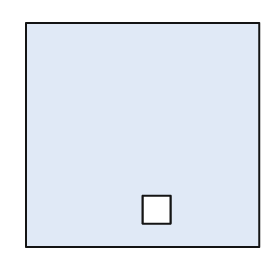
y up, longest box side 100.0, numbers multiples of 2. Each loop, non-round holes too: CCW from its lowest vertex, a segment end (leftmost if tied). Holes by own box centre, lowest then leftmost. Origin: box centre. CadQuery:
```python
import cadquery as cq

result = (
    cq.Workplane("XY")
    .moveTo(-50.0, -48.0)
    .lineTo(50.0, -48.0)
    .lineTo(50.0, 48.0)
    .lineTo(-50.0, 48.0)
    .close()
    .moveTo(0.0, -38.0)
    .lineTo(12.0, -38.0)
    .lineTo(12.0, -26.0)
    .lineTo(0.0, -26.0)
    .close()
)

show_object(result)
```